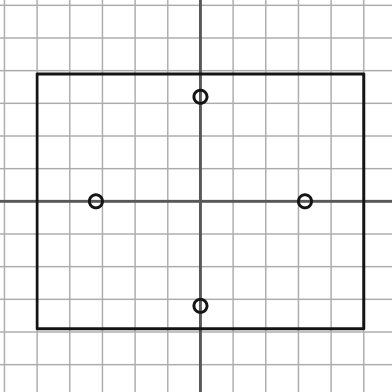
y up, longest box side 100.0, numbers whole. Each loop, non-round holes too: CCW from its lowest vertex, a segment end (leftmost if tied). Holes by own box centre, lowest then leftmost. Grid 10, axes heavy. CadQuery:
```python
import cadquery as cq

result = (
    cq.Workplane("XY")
    .moveTo(-50.0, -39.0)
    .lineTo(50.0, -39.0)
    .lineTo(50.0, 39.0)
    .lineTo(-50.0, 39.0)
    .close()
    .moveTo(0.0, -32.0)
    .circle(2.0)
    .moveTo(-32.0, 0.0)
    .circle(2.0)
    .moveTo(32.0, 0.0)
    .circle(2.0)
    .moveTo(0.0, 32.0)
    .circle(2.0)
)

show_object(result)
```